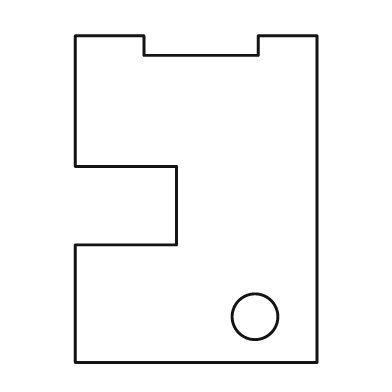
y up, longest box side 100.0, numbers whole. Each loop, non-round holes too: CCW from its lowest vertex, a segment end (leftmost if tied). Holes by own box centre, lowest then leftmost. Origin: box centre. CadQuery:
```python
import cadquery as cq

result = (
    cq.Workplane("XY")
    .moveTo(-37.0, -50.0)
    .lineTo(37.0, -50.0)
    .lineTo(37.0, 50.0)
    .lineTo(19.0, 50.0)
    .lineTo(19.0, 44.0)
    .lineTo(-16.0, 44.0)
    .lineTo(-16.0, 50.0)
    .lineTo(-37.0, 50.0)
    .lineTo(-37.0, 10.0)
    .lineTo(-6.0, 10.0)
    .lineTo(-6.0, -14.0)
    .lineTo(-37.0, -14.0)
    .close()
    .moveTo(18.0, -36.0)
    .circle(7.0)
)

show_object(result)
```